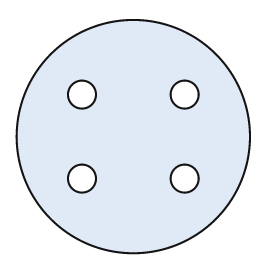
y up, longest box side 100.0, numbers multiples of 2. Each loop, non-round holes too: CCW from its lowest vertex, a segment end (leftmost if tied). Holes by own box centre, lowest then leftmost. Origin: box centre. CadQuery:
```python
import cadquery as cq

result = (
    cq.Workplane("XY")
    .moveTo(0.0, 0.0)
    .circle(50.0)
    .moveTo(-22.0, -18.0)
    .circle(6.0)
    .moveTo(22.0, -18.0)
    .circle(6.0)
    .moveTo(-22.0, 18.0)
    .circle(6.0)
    .moveTo(22.0, 18.0)
    .circle(6.0)
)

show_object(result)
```